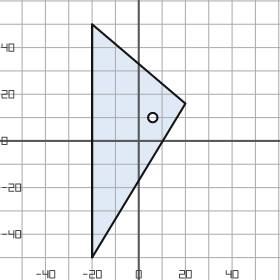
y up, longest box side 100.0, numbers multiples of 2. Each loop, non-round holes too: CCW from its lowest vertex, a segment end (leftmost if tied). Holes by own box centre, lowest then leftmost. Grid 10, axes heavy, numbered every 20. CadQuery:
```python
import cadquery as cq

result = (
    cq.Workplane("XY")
    .moveTo(-20.0, -50.0)
    .lineTo(20.0, 16.0)
    .lineTo(-20.0, 50.0)
    .close()
    .moveTo(6.0, 10.0)
    .circle(2.0)
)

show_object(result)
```